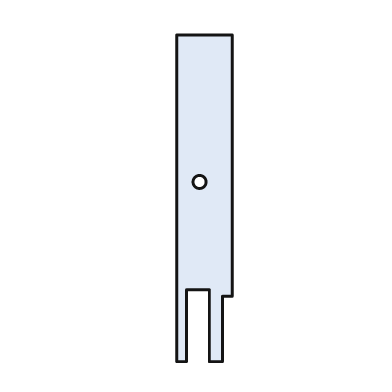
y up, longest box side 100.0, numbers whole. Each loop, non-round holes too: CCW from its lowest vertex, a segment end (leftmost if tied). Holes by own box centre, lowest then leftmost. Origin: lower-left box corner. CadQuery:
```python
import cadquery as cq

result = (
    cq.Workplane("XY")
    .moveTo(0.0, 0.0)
    .lineTo(3.0, 0.0)
    .lineTo(3.0, 22.0)
    .lineTo(10.0, 22.0)
    .lineTo(10.0, 0.0)
    .lineTo(14.0, 0.0)
    .lineTo(14.0, 20.0)
    .lineTo(17.0, 20.0)
    .lineTo(17.0, 100.0)
    .lineTo(0.0, 100.0)
    .close()
    .moveTo(7.0, 55.0)
    .circle(2.0)
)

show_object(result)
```